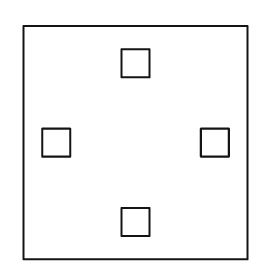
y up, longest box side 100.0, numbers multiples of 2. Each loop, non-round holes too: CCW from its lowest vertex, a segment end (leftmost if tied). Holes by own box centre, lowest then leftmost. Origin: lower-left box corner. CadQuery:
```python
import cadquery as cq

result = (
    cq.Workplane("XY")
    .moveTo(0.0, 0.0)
    .lineTo(96.0, 0.0)
    .lineTo(96.0, 100.0)
    .lineTo(0.0, 100.0)
    .close()
    .moveTo(42.0, 10.0)
    .lineTo(54.0, 10.0)
    .lineTo(54.0, 22.0)
    .lineTo(42.0, 22.0)
    .close()
    .moveTo(8.0, 44.0)
    .lineTo(20.0, 44.0)
    .lineTo(20.0, 56.0)
    .lineTo(8.0, 56.0)
    .close()
    .moveTo(76.0, 44.0)
    .lineTo(88.0, 44.0)
    .lineTo(88.0, 56.0)
    .lineTo(76.0, 56.0)
    .close()
    .moveTo(42.0, 78.0)
    .lineTo(54.0, 78.0)
    .lineTo(54.0, 90.0)
    .lineTo(42.0, 90.0)
    .close()
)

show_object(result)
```